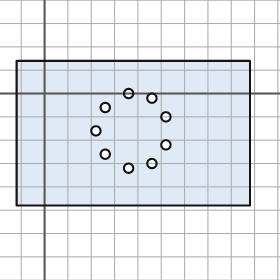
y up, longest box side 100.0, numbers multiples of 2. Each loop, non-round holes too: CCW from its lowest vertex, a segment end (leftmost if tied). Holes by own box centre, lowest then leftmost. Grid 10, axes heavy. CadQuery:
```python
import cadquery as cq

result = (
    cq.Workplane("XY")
    .moveTo(-12.0, -48.0)
    .lineTo(88.0, -48.0)
    .lineTo(88.0, 14.0)
    .lineTo(-12.0, 14.0)
    .close()
    .moveTo(36.0, -32.0)
    .circle(2.0)
    .moveTo(46.0, -30.0)
    .circle(2.0)
    .moveTo(26.0, -26.0)
    .circle(2.0)
    .moveTo(52.0, -22.0)
    .circle(2.0)
    .moveTo(22.0, -16.0)
    .circle(2.0)
    .moveTo(52.0, -10.0)
    .circle(2.0)
    .moveTo(26.0, -6.0)
    .circle(2.0)
    .moveTo(46.0, -2.0)
    .circle(2.0)
    .moveTo(36.0, 0.0)
    .circle(2.0)
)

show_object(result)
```